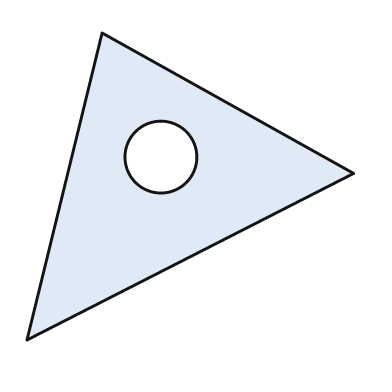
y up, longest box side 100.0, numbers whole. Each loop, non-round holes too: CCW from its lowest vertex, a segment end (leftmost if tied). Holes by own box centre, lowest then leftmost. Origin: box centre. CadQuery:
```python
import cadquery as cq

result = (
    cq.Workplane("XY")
    .moveTo(-50.0, -47.0)
    .lineTo(50.0, 4.0)
    .lineTo(-27.0, 47.0)
    .close()
    .moveTo(-9.0, 9.0)
    .circle(11.0)
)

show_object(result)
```